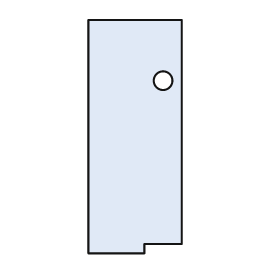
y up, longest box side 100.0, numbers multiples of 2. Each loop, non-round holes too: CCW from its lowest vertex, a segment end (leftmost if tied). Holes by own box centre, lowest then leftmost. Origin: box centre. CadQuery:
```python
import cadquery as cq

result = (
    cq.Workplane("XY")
    .moveTo(-20.0, -50.0)
    .lineTo(4.0, -50.0)
    .lineTo(4.0, -46.0)
    .lineTo(20.0, -46.0)
    .lineTo(20.0, 50.0)
    .lineTo(-20.0, 50.0)
    .close()
    .moveTo(12.0, 24.0)
    .circle(4.0)
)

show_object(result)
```